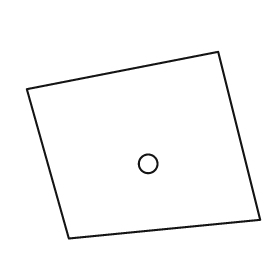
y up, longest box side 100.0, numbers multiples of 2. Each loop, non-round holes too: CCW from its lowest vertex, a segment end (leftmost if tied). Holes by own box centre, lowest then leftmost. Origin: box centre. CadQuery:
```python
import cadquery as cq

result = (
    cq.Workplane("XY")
    .moveTo(-32.0, -40.0)
    .lineTo(50.0, -32.0)
    .lineTo(32.0, 40.0)
    .lineTo(-50.0, 24.0)
    .close()
    .moveTo(2.0, -8.0)
    .circle(4.0)
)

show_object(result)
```